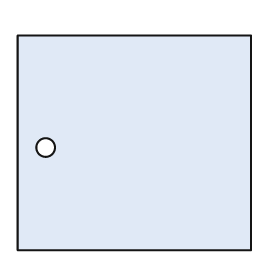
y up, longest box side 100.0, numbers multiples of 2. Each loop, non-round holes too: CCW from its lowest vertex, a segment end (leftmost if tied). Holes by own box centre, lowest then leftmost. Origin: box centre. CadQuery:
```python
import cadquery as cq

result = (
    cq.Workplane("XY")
    .moveTo(-50.0, -46.0)
    .lineTo(50.0, -46.0)
    .lineTo(50.0, 46.0)
    .lineTo(-50.0, 46.0)
    .close()
    .moveTo(-38.0, -2.0)
    .circle(4.0)
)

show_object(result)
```